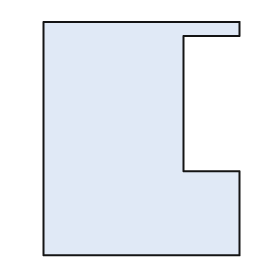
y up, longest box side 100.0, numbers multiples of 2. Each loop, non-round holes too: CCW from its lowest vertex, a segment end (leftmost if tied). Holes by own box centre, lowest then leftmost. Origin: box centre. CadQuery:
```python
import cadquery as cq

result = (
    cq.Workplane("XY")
    .moveTo(-42.0, -50.0)
    .lineTo(42.0, -50.0)
    .lineTo(42.0, -14.0)
    .lineTo(18.0, -14.0)
    .lineTo(18.0, 44.0)
    .lineTo(42.0, 44.0)
    .lineTo(42.0, 50.0)
    .lineTo(-42.0, 50.0)
    .close()
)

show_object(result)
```